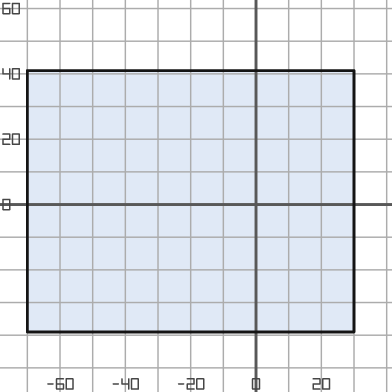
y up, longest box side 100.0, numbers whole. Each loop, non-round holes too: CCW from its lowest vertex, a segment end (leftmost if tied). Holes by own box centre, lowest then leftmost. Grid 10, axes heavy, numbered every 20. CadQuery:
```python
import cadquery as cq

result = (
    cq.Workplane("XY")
    .moveTo(-70.0, -39.0)
    .lineTo(30.0, -39.0)
    .lineTo(30.0, 41.0)
    .lineTo(-70.0, 41.0)
    .close()
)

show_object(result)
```